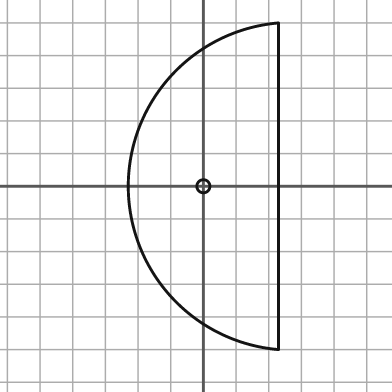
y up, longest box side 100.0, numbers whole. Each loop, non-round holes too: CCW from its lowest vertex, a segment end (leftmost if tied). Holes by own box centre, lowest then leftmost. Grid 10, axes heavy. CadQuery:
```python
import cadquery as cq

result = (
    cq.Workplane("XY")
    .moveTo(23.0, -50.0)
    .lineTo(23.0, 50.0)
    .threePointArc((-23.0, 0.0), (23.0, -50.0))
    .close()
    .moveTo(0.0, 0.0)
    .circle(2.0)
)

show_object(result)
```